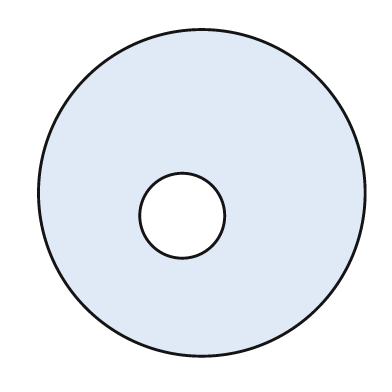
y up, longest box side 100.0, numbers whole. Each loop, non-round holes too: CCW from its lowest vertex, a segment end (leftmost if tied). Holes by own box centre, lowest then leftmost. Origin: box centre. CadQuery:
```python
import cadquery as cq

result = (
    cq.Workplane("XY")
    .moveTo(0.0, 0.0)
    .circle(50.0)
    .moveTo(-6.0, -7.0)
    .circle(13.0)
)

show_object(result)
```